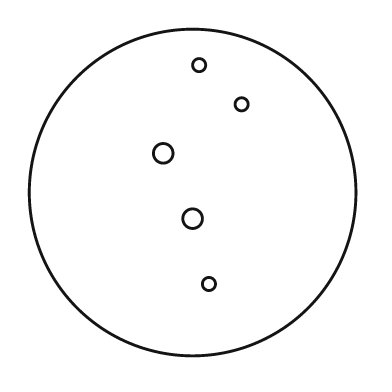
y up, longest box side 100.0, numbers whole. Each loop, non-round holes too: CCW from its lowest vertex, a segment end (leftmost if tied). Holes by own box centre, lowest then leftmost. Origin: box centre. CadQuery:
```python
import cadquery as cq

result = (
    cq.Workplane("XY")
    .moveTo(0.0, 0.0)
    .circle(50.0)
    .moveTo(5.0, -28.0)
    .circle(2.0)
    .moveTo(0.0, -8.0)
    .circle(3.0)
    .moveTo(-9.0, 12.0)
    .circle(3.0)
    .moveTo(15.0, 27.0)
    .circle(2.0)
    .moveTo(2.0, 39.0)
    .circle(2.0)
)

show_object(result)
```